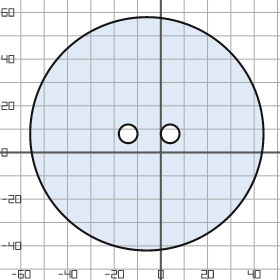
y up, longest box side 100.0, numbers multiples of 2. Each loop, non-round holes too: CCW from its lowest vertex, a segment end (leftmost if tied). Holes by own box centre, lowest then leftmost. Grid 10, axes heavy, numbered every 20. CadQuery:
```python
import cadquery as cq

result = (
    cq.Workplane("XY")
    .moveTo(-6.0, 8.0)
    .circle(50.0)
    .moveTo(-14.0, 8.0)
    .circle(4.0)
    .moveTo(4.0, 8.0)
    .circle(4.0)
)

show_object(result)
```